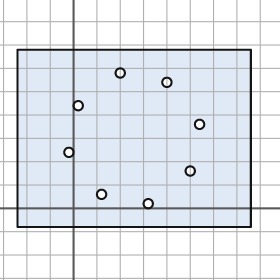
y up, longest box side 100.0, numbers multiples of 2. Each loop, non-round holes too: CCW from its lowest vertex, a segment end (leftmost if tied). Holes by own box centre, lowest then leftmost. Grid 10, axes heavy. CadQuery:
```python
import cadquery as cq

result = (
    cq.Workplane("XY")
    .moveTo(-24.0, -8.0)
    .lineTo(76.0, -8.0)
    .lineTo(76.0, 68.0)
    .lineTo(-24.0, 68.0)
    .close()
    .moveTo(32.0, 2.0)
    .circle(2.0)
    .moveTo(12.0, 6.0)
    .circle(2.0)
    .moveTo(50.0, 16.0)
    .circle(2.0)
    .moveTo(-2.0, 24.0)
    .circle(2.0)
    .moveTo(54.0, 36.0)
    .circle(2.0)
    .moveTo(2.0, 44.0)
    .circle(2.0)
    .moveTo(40.0, 54.0)
    .circle(2.0)
    .moveTo(20.0, 58.0)
    .circle(2.0)
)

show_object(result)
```